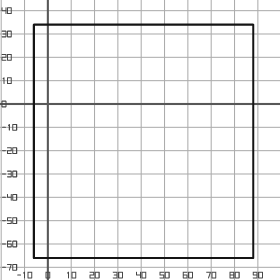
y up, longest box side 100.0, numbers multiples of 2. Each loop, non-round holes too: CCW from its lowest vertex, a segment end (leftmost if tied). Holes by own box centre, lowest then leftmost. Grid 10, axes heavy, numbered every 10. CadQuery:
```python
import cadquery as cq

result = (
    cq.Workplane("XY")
    .moveTo(-6.0, -66.0)
    .lineTo(88.0, -66.0)
    .lineTo(88.0, 34.0)
    .lineTo(-6.0, 34.0)
    .close()
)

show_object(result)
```